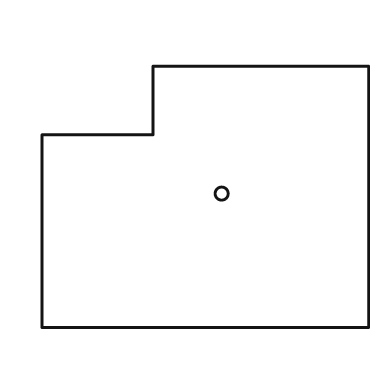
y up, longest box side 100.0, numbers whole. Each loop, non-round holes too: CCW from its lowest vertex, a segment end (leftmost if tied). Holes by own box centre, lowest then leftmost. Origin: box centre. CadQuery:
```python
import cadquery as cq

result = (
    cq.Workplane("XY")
    .moveTo(-50.0, -40.0)
    .lineTo(50.0, -40.0)
    .lineTo(50.0, 40.0)
    .lineTo(-16.0, 40.0)
    .lineTo(-16.0, 19.0)
    .lineTo(-50.0, 19.0)
    .close()
    .moveTo(5.0, 1.0)
    .circle(2.0)
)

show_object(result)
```